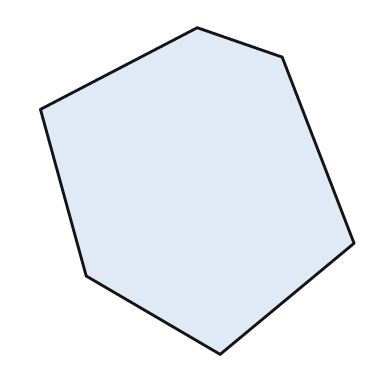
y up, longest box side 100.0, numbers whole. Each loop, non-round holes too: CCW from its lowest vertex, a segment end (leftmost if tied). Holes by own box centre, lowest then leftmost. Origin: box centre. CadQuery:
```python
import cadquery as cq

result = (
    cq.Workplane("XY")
    .moveTo(7.0, -50.0)
    .lineTo(48.0, -16.0)
    .lineTo(26.0, 41.0)
    .lineTo(0.0, 50.0)
    .lineTo(-48.0, 25.0)
    .lineTo(-34.0, -26.0)
    .close()
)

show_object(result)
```